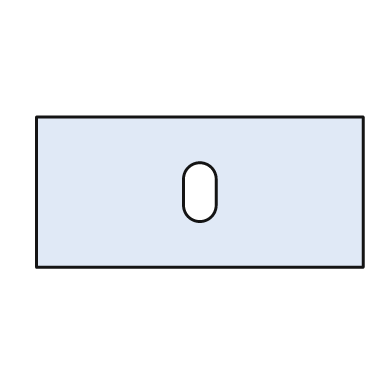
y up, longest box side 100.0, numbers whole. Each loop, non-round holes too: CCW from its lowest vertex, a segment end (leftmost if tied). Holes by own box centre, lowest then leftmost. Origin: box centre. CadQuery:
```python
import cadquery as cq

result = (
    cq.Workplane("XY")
    .moveTo(-50.0, -23.0)
    .lineTo(50.0, -23.0)
    .lineTo(50.0, 23.0)
    .lineTo(-50.0, 23.0)
    .close()
    .moveTo(-5.0, -4.0)
    .threePointArc((0.0, -9.0), (5.0, -4.0))
    .lineTo(5.0, 4.0)
    .threePointArc((0.0, 9.0), (-5.0, 4.0))
    .close()
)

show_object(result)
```